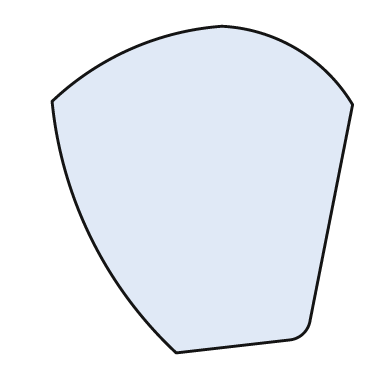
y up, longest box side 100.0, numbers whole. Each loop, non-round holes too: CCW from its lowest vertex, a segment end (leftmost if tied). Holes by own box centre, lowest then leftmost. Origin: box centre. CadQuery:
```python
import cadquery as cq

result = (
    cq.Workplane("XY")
    .moveTo(-8.0, -50.0)
    .lineTo(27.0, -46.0)
    .threePointArc((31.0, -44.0), (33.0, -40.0))
    .lineTo(46.0, 26.0)
    .threePointArc((29.0, 43.0), (6.0, 50.0))
    .threePointArc((-22.0, 43.0), (-46.0, 27.0))
    .threePointArc((-34.0, -15.0), (-8.0, -50.0))
    .close()
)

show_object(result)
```